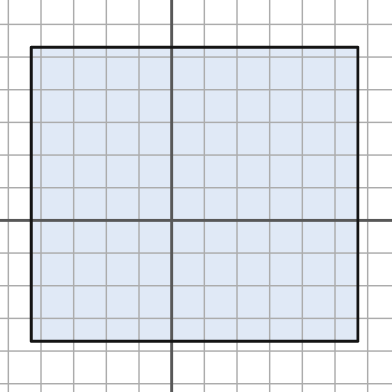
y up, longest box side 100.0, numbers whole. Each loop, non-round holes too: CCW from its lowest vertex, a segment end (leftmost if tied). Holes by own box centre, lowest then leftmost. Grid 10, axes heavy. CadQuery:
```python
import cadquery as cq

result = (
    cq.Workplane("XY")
    .moveTo(-43.0, -37.0)
    .lineTo(57.0, -37.0)
    .lineTo(57.0, 53.0)
    .lineTo(-43.0, 53.0)
    .close()
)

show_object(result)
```